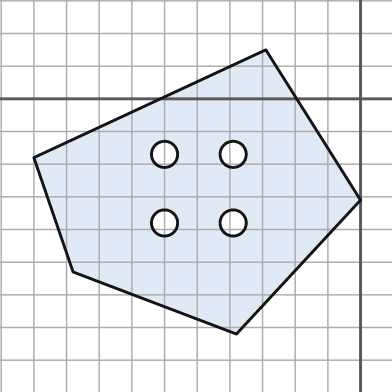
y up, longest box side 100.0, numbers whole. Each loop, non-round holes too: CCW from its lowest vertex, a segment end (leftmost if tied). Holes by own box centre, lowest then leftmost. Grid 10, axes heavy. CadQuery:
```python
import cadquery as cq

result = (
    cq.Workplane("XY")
    .moveTo(-38.0, -72.0)
    .lineTo(0.0, -31.0)
    .lineTo(-29.0, 15.0)
    .lineTo(-100.0, -18.0)
    .lineTo(-88.0, -53.0)
    .close()
    .moveTo(-60.0, -38.0)
    .circle(4.0)
    .moveTo(-39.0, -38.0)
    .circle(4.0)
    .moveTo(-60.0, -17.0)
    .circle(4.0)
    .moveTo(-39.0, -17.0)
    .circle(4.0)
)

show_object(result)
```